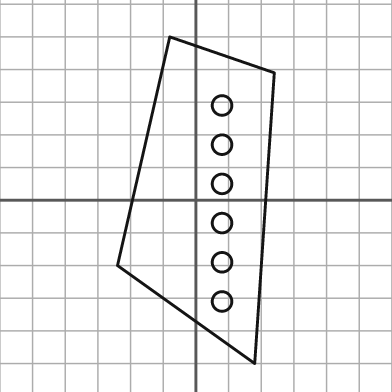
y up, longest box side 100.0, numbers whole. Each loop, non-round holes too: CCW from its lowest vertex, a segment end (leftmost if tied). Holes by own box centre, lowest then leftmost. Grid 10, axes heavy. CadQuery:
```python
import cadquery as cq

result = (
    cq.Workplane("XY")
    .moveTo(18.0, -50.0)
    .lineTo(24.0, 39.0)
    .lineTo(-8.0, 50.0)
    .lineTo(-24.0, -20.0)
    .close()
    .moveTo(8.0, -31.0)
    .circle(3.0)
    .moveTo(8.0, -19.0)
    .circle(3.0)
    .moveTo(8.0, -7.0)
    .circle(3.0)
    .moveTo(8.0, 5.0)
    .circle(3.0)
    .moveTo(8.0, 17.0)
    .circle(3.0)
    .moveTo(8.0, 29.0)
    .circle(3.0)
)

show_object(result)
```